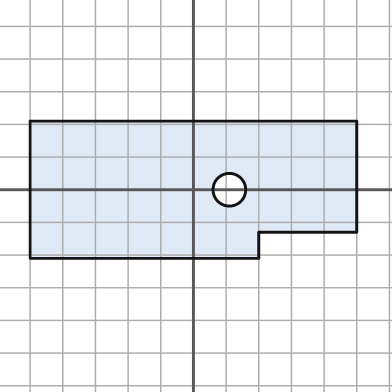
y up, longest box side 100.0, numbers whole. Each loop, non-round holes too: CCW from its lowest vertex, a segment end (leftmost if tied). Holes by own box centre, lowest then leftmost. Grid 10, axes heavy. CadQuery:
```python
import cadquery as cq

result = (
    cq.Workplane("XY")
    .moveTo(-50.0, -21.0)
    .lineTo(20.0, -21.0)
    .lineTo(20.0, -13.0)
    .lineTo(50.0, -13.0)
    .lineTo(50.0, 21.0)
    .lineTo(-50.0, 21.0)
    .close()
    .moveTo(11.0, 0.0)
    .circle(5.0)
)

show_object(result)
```